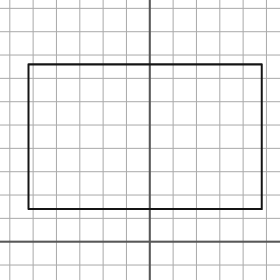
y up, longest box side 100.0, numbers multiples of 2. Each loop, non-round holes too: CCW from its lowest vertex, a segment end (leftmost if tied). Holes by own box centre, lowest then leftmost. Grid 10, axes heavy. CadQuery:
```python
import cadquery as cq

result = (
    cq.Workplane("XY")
    .moveTo(-52.0, 14.0)
    .lineTo(48.0, 14.0)
    .lineTo(48.0, 76.0)
    .lineTo(-52.0, 76.0)
    .close()
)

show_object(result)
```